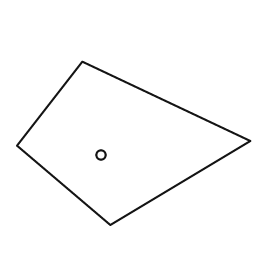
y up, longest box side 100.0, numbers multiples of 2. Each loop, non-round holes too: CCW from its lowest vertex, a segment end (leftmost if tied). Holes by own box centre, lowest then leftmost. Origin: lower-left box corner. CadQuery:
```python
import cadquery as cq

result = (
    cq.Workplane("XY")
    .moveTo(40.0, 0.0)
    .lineTo(100.0, 36.0)
    .lineTo(28.0, 70.0)
    .lineTo(0.0, 34.0)
    .close()
    .moveTo(36.0, 30.0)
    .circle(2.0)
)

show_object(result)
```